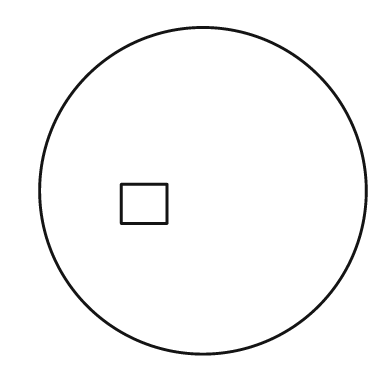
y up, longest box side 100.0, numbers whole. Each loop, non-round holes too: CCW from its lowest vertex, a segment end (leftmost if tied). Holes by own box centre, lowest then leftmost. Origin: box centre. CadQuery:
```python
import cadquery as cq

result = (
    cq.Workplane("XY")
    .moveTo(0.0, 0.0)
    .circle(50.0)
    .moveTo(-25.0, -10.0)
    .lineTo(-11.0, -10.0)
    .lineTo(-11.0, 2.0)
    .lineTo(-25.0, 2.0)
    .close()
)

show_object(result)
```